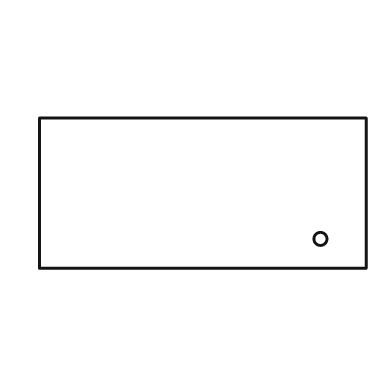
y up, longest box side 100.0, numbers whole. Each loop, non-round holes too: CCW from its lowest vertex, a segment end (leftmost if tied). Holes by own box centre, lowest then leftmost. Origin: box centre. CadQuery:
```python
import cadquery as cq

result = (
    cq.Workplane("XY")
    .moveTo(-50.0, -23.0)
    .lineTo(50.0, -23.0)
    .lineTo(50.0, 23.0)
    .lineTo(-50.0, 23.0)
    .close()
    .moveTo(36.0, -14.0)
    .circle(2.0)
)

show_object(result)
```